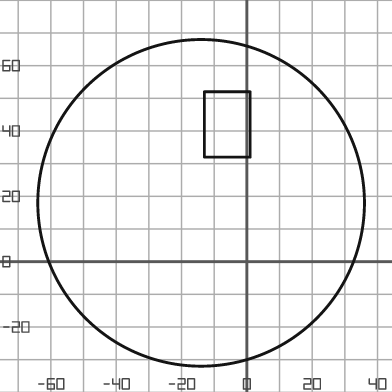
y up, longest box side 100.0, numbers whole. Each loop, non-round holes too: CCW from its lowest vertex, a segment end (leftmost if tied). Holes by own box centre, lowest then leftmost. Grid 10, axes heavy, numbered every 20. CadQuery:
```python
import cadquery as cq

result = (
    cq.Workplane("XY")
    .moveTo(-14.0, 18.0)
    .circle(50.0)
    .moveTo(-13.0, 32.0)
    .lineTo(1.0, 32.0)
    .lineTo(1.0, 52.0)
    .lineTo(-13.0, 52.0)
    .close()
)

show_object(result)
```